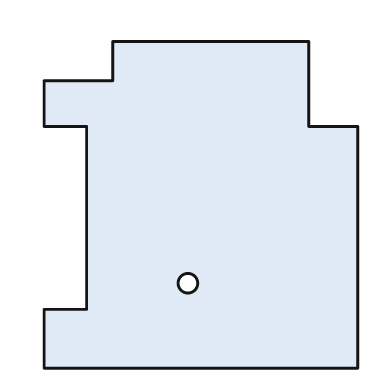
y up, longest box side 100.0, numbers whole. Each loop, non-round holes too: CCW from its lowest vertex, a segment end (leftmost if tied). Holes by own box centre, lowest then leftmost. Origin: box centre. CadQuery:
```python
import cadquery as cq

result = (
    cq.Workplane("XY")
    .moveTo(-48.0, -50.0)
    .lineTo(48.0, -50.0)
    .lineTo(48.0, 24.0)
    .lineTo(33.0, 24.0)
    .lineTo(33.0, 50.0)
    .lineTo(-27.0, 50.0)
    .lineTo(-27.0, 38.0)
    .lineTo(-48.0, 38.0)
    .lineTo(-48.0, 24.0)
    .lineTo(-35.0, 24.0)
    .lineTo(-35.0, -32.0)
    .lineTo(-48.0, -32.0)
    .close()
    .moveTo(-4.0, -24.0)
    .circle(3.0)
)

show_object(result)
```